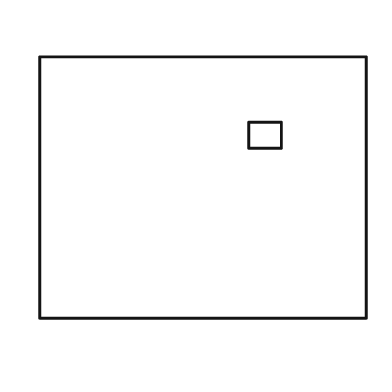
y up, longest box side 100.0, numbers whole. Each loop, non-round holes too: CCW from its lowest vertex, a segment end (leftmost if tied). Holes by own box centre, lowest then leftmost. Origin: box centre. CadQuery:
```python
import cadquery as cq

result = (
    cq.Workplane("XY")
    .moveTo(-50.0, -40.0)
    .lineTo(50.0, -40.0)
    .lineTo(50.0, 40.0)
    .lineTo(-50.0, 40.0)
    .close()
    .moveTo(14.0, 12.0)
    .lineTo(24.0, 12.0)
    .lineTo(24.0, 20.0)
    .lineTo(14.0, 20.0)
    .close()
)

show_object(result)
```